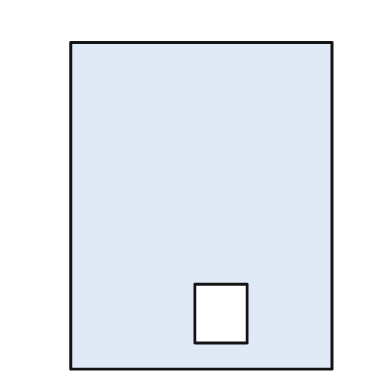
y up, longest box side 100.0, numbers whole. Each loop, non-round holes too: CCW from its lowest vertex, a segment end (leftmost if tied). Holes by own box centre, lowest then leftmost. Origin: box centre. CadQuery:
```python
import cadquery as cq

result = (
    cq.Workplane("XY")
    .moveTo(-40.0, -50.0)
    .lineTo(40.0, -50.0)
    .lineTo(40.0, 50.0)
    .lineTo(-40.0, 50.0)
    .close()
    .moveTo(-2.0, -42.0)
    .lineTo(14.0, -42.0)
    .lineTo(14.0, -24.0)
    .lineTo(-2.0, -24.0)
    .close()
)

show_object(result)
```